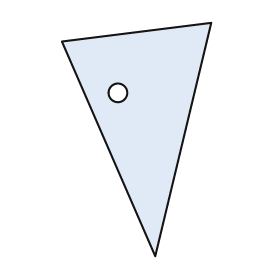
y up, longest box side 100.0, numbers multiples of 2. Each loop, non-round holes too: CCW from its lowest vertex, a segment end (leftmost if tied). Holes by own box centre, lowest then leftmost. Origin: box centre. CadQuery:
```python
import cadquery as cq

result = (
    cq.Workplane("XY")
    .moveTo(8.0, -50.0)
    .lineTo(32.0, 50.0)
    .lineTo(-32.0, 42.0)
    .close()
    .moveTo(-8.0, 20.0)
    .circle(4.0)
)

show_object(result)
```